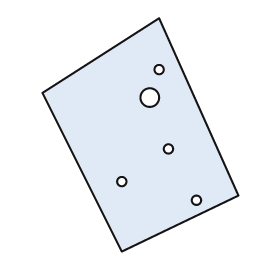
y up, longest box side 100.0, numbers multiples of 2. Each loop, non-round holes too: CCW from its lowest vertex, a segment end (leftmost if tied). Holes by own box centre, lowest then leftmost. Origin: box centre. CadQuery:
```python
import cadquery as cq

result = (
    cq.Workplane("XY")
    .moveTo(-8.0, -50.0)
    .lineTo(42.0, -26.0)
    .lineTo(8.0, 50.0)
    .lineTo(-42.0, 18.0)
    .close()
    .moveTo(24.0, -28.0)
    .circle(2.0)
    .moveTo(-8.0, -20.0)
    .circle(2.0)
    .moveTo(12.0, -6.0)
    .circle(2.0)
    .moveTo(4.0, 16.0)
    .circle(4.0)
    .moveTo(8.0, 28.0)
    .circle(2.0)
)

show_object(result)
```